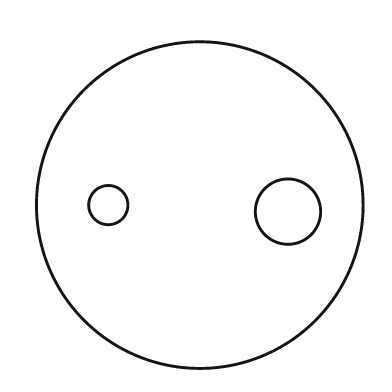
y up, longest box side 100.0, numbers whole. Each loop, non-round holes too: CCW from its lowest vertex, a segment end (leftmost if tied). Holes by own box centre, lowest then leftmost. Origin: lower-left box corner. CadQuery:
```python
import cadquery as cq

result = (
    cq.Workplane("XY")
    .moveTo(50.0, 50.0)
    .circle(50.0)
    .moveTo(77.0, 48.0)
    .circle(10.0)
    .moveTo(22.0, 50.0)
    .circle(6.0)
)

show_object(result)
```